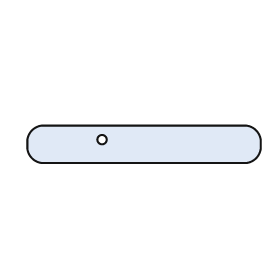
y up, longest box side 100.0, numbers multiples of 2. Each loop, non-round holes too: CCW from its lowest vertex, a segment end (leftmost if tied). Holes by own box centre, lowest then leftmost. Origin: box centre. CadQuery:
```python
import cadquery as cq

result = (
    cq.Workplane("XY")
    .moveTo(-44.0, -8.0)
    .lineTo(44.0, -8.0)
    .threePointArc((48.0, -6.0), (50.0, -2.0))
    .lineTo(50.0, 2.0)
    .threePointArc((48.0, 6.0), (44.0, 8.0))
    .lineTo(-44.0, 8.0)
    .threePointArc((-48.0, 6.0), (-50.0, 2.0))
    .lineTo(-50.0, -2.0)
    .threePointArc((-48.0, -6.0), (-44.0, -8.0))
    .close()
    .moveTo(-18.0, 2.0)
    .circle(2.0)
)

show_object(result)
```